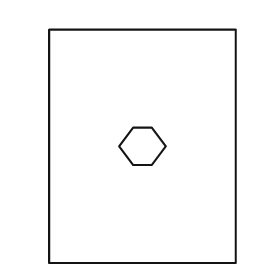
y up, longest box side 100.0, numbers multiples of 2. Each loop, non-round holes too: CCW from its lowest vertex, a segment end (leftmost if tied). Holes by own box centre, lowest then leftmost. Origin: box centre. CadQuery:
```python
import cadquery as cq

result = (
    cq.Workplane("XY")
    .moveTo(-40.0, -50.0)
    .lineTo(40.0, -50.0)
    .lineTo(40.0, 50.0)
    .lineTo(-40.0, 50.0)
    .close()
    .moveTo(-4.0, -8.0)
    .lineTo(4.0, -8.0)
    .lineTo(10.0, 0.0)
    .lineTo(4.0, 8.0)
    .lineTo(-4.0, 8.0)
    .lineTo(-10.0, 0.0)
    .close()
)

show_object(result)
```